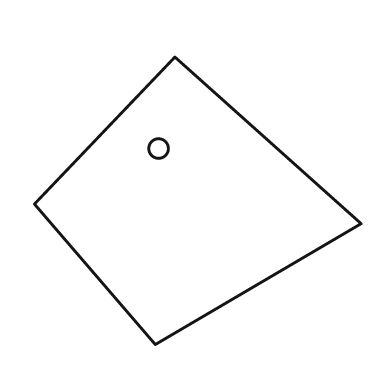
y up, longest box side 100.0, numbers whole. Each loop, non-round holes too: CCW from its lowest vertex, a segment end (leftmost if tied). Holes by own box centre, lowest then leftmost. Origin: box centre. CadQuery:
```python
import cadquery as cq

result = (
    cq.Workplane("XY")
    .moveTo(-13.0, -44.0)
    .lineTo(50.0, -7.0)
    .lineTo(-7.0, 44.0)
    .lineTo(-50.0, -1.0)
    .close()
    .moveTo(-12.0, 16.0)
    .circle(3.0)
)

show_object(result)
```